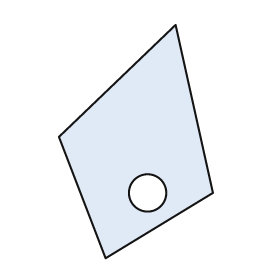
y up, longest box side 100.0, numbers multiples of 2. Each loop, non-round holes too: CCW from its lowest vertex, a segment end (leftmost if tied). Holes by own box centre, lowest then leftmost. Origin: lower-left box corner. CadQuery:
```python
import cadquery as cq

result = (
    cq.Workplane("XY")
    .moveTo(20.0, 0.0)
    .lineTo(66.0, 28.0)
    .lineTo(50.0, 100.0)
    .lineTo(0.0, 52.0)
    .close()
    .moveTo(38.0, 28.0)
    .circle(8.0)
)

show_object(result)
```